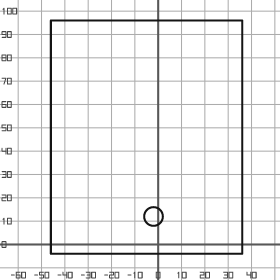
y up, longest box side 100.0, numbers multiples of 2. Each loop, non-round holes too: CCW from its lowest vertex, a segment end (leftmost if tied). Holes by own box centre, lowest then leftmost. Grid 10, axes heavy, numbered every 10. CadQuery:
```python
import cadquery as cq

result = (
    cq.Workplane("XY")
    .moveTo(-46.0, -4.0)
    .lineTo(36.0, -4.0)
    .lineTo(36.0, 96.0)
    .lineTo(-46.0, 96.0)
    .close()
    .moveTo(-2.0, 12.0)
    .circle(4.0)
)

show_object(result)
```